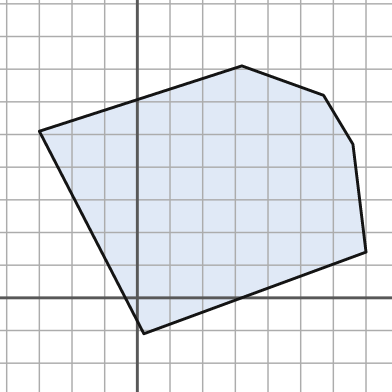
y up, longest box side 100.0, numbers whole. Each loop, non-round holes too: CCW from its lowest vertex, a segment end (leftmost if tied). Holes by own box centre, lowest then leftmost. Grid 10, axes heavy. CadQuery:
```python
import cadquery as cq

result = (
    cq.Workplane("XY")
    .moveTo(2.0, -11.0)
    .lineTo(70.0, 14.0)
    .lineTo(66.0, 47.0)
    .lineTo(57.0, 62.0)
    .lineTo(32.0, 71.0)
    .lineTo(-30.0, 51.0)
    .close()
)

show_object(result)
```